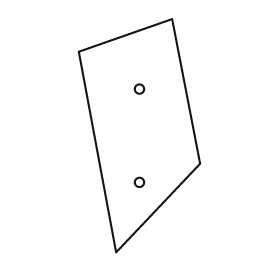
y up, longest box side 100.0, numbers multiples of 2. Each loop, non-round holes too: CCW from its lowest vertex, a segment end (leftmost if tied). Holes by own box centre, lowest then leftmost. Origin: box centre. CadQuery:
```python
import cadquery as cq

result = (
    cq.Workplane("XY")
    .moveTo(-10.0, -50.0)
    .lineTo(26.0, -12.0)
    .lineTo(14.0, 50.0)
    .lineTo(-26.0, 36.0)
    .close()
    .moveTo(0.0, -20.0)
    .circle(2.0)
    .moveTo(0.0, 20.0)
    .circle(2.0)
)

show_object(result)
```